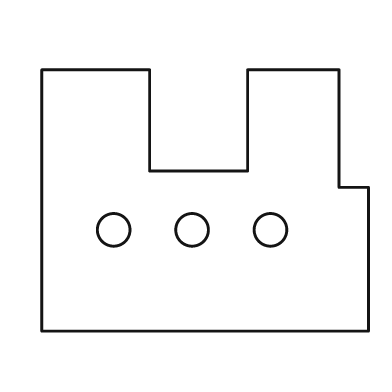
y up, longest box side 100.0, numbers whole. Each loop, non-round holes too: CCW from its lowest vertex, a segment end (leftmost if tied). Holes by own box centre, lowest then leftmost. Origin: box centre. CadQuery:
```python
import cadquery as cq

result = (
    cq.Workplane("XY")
    .moveTo(-50.0, -40.0)
    .lineTo(50.0, -40.0)
    .lineTo(50.0, 4.0)
    .lineTo(41.0, 4.0)
    .lineTo(41.0, 40.0)
    .lineTo(13.0, 40.0)
    .lineTo(13.0, 9.0)
    .lineTo(-17.0, 9.0)
    .lineTo(-17.0, 40.0)
    .lineTo(-50.0, 40.0)
    .close()
    .moveTo(-28.0, -9.0)
    .circle(5.0)
    .moveTo(-4.0, -9.0)
    .circle(5.0)
    .moveTo(20.0, -9.0)
    .circle(5.0)
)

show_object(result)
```